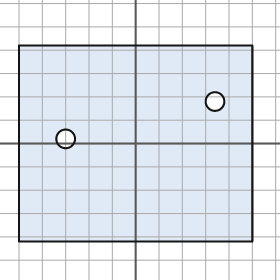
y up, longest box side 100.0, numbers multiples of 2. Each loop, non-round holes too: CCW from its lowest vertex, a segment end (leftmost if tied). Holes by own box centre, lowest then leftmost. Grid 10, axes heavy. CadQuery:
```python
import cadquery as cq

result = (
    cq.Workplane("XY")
    .moveTo(-50.0, -42.0)
    .lineTo(50.0, -42.0)
    .lineTo(50.0, 42.0)
    .lineTo(-50.0, 42.0)
    .close()
    .moveTo(-30.0, 2.0)
    .circle(4.0)
    .moveTo(34.0, 18.0)
    .circle(4.0)
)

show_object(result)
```